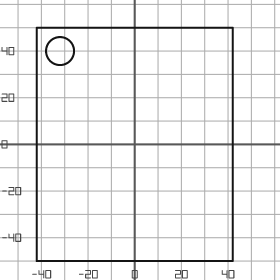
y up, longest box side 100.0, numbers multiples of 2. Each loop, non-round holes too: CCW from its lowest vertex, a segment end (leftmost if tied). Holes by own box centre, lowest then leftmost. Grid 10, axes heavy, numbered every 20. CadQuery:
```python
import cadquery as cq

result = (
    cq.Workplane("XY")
    .moveTo(-42.0, -50.0)
    .lineTo(42.0, -50.0)
    .lineTo(42.0, 50.0)
    .lineTo(-42.0, 50.0)
    .close()
    .moveTo(-32.0, 40.0)
    .circle(6.0)
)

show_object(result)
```